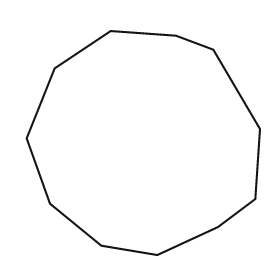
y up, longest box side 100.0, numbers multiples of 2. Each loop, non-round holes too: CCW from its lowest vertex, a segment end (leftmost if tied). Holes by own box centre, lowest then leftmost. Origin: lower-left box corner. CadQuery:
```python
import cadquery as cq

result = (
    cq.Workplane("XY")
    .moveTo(56.0, 0.0)
    .lineTo(82.0, 12.0)
    .lineTo(98.0, 24.0)
    .lineTo(100.0, 54.0)
    .lineTo(80.0, 88.0)
    .lineTo(64.0, 94.0)
    .lineTo(36.0, 96.0)
    .lineTo(12.0, 80.0)
    .lineTo(0.0, 50.0)
    .lineTo(10.0, 22.0)
    .lineTo(32.0, 4.0)
    .close()
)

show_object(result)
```